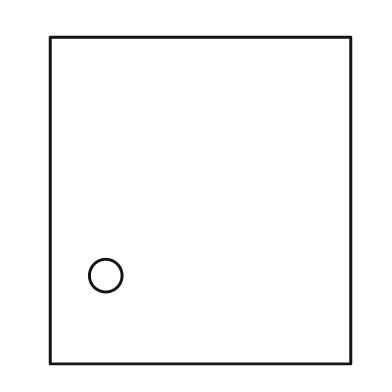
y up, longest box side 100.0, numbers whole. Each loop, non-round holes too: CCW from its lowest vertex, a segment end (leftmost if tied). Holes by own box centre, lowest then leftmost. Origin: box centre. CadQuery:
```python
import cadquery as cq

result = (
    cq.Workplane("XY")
    .moveTo(-46.0, -50.0)
    .lineTo(46.0, -50.0)
    .lineTo(46.0, 50.0)
    .lineTo(-46.0, 50.0)
    .close()
    .moveTo(-29.0, -23.0)
    .circle(5.0)
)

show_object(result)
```